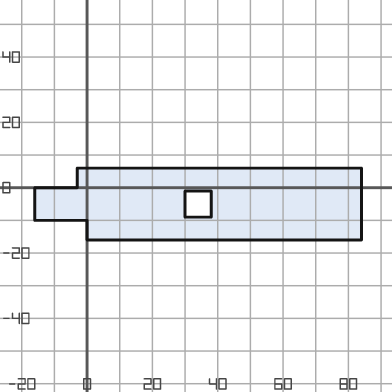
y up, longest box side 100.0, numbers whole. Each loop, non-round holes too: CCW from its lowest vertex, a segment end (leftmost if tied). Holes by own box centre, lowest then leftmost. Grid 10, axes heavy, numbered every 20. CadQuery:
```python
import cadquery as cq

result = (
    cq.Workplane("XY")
    .moveTo(0.0, -16.0)
    .lineTo(84.0, -16.0)
    .lineTo(84.0, 6.0)
    .lineTo(-3.0, 6.0)
    .lineTo(-3.0, 0.0)
    .lineTo(-16.0, 0.0)
    .lineTo(-16.0, -10.0)
    .lineTo(0.0, -10.0)
    .close()
    .moveTo(30.0, -9.0)
    .lineTo(38.0, -9.0)
    .lineTo(38.0, -1.0)
    .lineTo(30.0, -1.0)
    .close()
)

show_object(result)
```